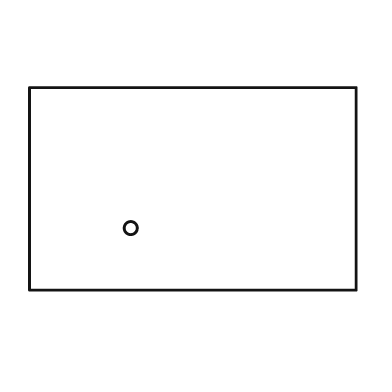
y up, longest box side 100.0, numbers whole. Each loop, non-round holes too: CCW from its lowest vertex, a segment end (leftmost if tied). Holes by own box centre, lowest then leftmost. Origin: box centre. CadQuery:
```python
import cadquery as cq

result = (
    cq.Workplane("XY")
    .moveTo(-50.0, -31.0)
    .lineTo(50.0, -31.0)
    .lineTo(50.0, 31.0)
    .lineTo(-50.0, 31.0)
    .close()
    .moveTo(-19.0, -12.0)
    .circle(2.0)
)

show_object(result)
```